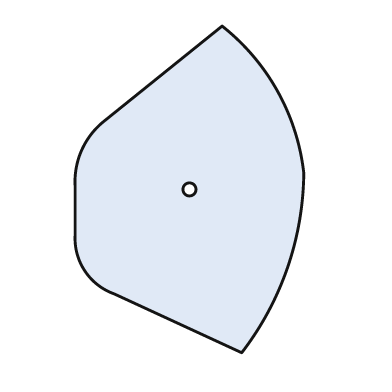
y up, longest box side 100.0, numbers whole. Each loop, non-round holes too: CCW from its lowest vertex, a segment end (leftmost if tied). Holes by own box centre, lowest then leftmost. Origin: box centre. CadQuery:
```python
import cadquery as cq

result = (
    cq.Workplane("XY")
    .moveTo(16.0, -50.0)
    .threePointArc((30.0, -24.0), (35.0, 5.0))
    .threePointArc((27.0, 30.0), (10.0, 50.0))
    .lineTo(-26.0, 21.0)
    .threePointArc((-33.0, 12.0), (-35.0, 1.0))
    .lineTo(-35.0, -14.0)
    .threePointArc((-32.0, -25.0), (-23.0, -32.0))
    .close()
    .moveTo(0.0, 0.0)
    .circle(2.0)
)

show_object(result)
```